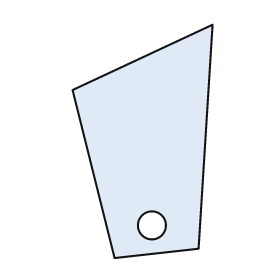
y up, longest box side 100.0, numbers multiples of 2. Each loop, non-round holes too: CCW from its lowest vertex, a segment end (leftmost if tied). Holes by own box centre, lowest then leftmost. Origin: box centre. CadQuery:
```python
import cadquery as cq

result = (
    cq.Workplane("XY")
    .moveTo(-12.0, -50.0)
    .lineTo(24.0, -46.0)
    .lineTo(30.0, 50.0)
    .lineTo(-30.0, 22.0)
    .close()
    .moveTo(4.0, -36.0)
    .circle(6.0)
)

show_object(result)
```